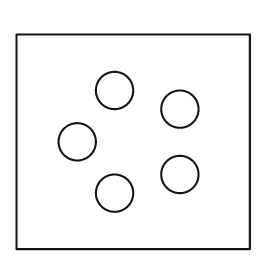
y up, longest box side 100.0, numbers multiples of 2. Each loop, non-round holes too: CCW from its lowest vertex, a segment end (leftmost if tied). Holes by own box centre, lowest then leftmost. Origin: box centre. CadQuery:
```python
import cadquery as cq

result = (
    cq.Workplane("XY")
    .moveTo(-50.0, -46.0)
    .lineTo(50.0, -46.0)
    .lineTo(50.0, 46.0)
    .lineTo(-50.0, 46.0)
    .close()
    .moveTo(-8.0, -22.0)
    .circle(8.0)
    .moveTo(20.0, -14.0)
    .circle(8.0)
    .moveTo(-24.0, 0.0)
    .circle(8.0)
    .moveTo(20.0, 14.0)
    .circle(8.0)
    .moveTo(-8.0, 22.0)
    .circle(8.0)
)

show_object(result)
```